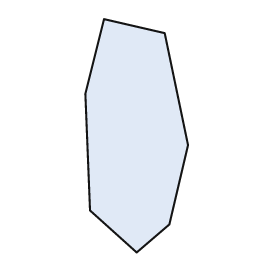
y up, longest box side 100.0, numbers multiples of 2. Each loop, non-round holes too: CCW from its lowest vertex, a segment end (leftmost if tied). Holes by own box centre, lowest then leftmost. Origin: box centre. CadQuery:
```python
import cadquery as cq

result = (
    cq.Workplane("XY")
    .moveTo(0.0, -50.0)
    .lineTo(14.0, -38.0)
    .lineTo(22.0, -4.0)
    .lineTo(12.0, 44.0)
    .lineTo(-14.0, 50.0)
    .lineTo(-22.0, 18.0)
    .lineTo(-20.0, -32.0)
    .close()
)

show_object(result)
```